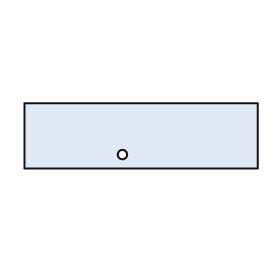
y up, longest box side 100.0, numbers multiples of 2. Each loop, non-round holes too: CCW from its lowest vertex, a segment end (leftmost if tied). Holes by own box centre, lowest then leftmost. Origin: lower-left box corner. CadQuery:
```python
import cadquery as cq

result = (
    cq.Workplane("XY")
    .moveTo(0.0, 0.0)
    .lineTo(100.0, 0.0)
    .lineTo(100.0, 28.0)
    .lineTo(0.0, 28.0)
    .close()
    .moveTo(42.0, 6.0)
    .circle(2.0)
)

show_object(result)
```